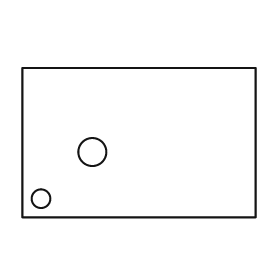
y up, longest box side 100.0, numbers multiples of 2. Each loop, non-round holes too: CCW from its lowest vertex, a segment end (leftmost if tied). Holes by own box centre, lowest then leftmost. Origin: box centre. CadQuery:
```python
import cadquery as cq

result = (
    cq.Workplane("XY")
    .moveTo(-50.0, -32.0)
    .lineTo(50.0, -32.0)
    .lineTo(50.0, 32.0)
    .lineTo(-50.0, 32.0)
    .close()
    .moveTo(-42.0, -24.0)
    .circle(4.0)
    .moveTo(-20.0, -4.0)
    .circle(6.0)
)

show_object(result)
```